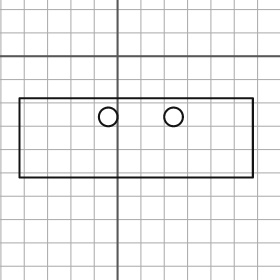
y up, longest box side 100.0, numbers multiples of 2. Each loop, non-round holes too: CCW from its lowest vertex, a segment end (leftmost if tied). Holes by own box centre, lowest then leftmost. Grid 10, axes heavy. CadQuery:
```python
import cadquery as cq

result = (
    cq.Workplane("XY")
    .moveTo(-42.0, -52.0)
    .lineTo(58.0, -52.0)
    .lineTo(58.0, -18.0)
    .lineTo(-42.0, -18.0)
    .close()
    .moveTo(-4.0, -26.0)
    .circle(4.0)
    .moveTo(24.0, -26.0)
    .circle(4.0)
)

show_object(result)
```